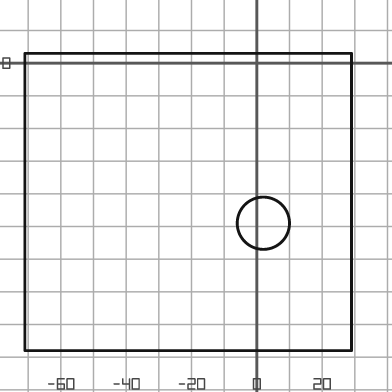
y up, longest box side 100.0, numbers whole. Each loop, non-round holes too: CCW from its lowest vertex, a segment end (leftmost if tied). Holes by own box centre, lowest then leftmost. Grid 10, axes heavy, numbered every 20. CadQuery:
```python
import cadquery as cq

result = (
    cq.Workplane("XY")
    .moveTo(-71.0, -88.0)
    .lineTo(29.0, -88.0)
    .lineTo(29.0, 3.0)
    .lineTo(-71.0, 3.0)
    .close()
    .moveTo(2.0, -49.0)
    .circle(8.0)
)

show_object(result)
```